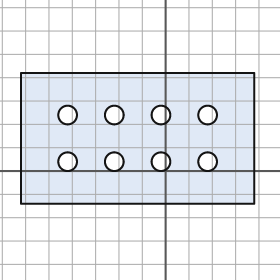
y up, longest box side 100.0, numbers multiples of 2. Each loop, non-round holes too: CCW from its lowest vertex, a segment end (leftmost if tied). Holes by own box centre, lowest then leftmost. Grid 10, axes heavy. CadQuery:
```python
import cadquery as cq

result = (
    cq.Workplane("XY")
    .moveTo(-62.0, -14.0)
    .lineTo(38.0, -14.0)
    .lineTo(38.0, 42.0)
    .lineTo(-62.0, 42.0)
    .close()
    .moveTo(-42.0, 4.0)
    .circle(4.0)
    .moveTo(-22.0, 4.0)
    .circle(4.0)
    .moveTo(-2.0, 4.0)
    .circle(4.0)
    .moveTo(18.0, 4.0)
    .circle(4.0)
    .moveTo(-42.0, 24.0)
    .circle(4.0)
    .moveTo(-22.0, 24.0)
    .circle(4.0)
    .moveTo(-2.0, 24.0)
    .circle(4.0)
    .moveTo(18.0, 24.0)
    .circle(4.0)
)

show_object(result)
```